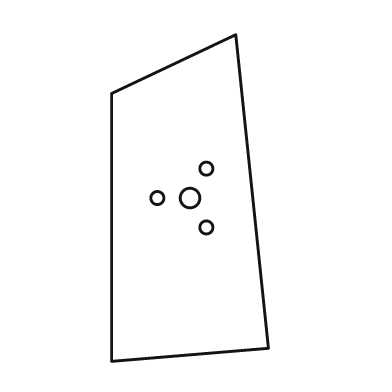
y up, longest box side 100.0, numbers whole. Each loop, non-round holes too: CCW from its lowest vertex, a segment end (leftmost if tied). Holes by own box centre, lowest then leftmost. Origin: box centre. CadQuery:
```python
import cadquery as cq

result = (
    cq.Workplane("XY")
    .moveTo(-24.0, -50.0)
    .lineTo(24.0, -46.0)
    .lineTo(14.0, 50.0)
    .lineTo(-24.0, 32.0)
    .close()
    .moveTo(5.0, -9.0)
    .circle(2.0)
    .moveTo(-10.0, 0.0)
    .circle(2.0)
    .moveTo(0.0, 0.0)
    .circle(3.0)
    .moveTo(5.0, 9.0)
    .circle(2.0)
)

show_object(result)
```